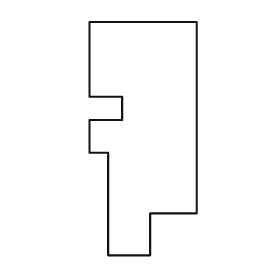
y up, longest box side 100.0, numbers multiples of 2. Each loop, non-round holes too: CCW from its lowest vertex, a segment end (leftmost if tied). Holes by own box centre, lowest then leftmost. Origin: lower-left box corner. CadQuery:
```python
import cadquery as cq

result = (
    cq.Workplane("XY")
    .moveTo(8.0, 0.0)
    .lineTo(26.0, 0.0)
    .lineTo(26.0, 18.0)
    .lineTo(46.0, 18.0)
    .lineTo(46.0, 100.0)
    .lineTo(0.0, 100.0)
    .lineTo(0.0, 68.0)
    .lineTo(14.0, 68.0)
    .lineTo(14.0, 58.0)
    .lineTo(0.0, 58.0)
    .lineTo(0.0, 44.0)
    .lineTo(8.0, 44.0)
    .close()
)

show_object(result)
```